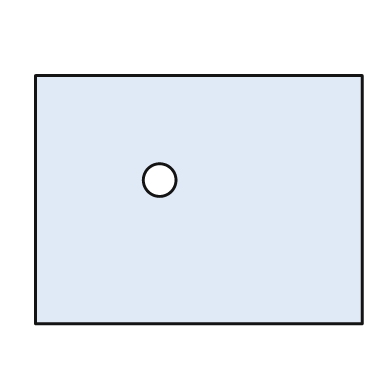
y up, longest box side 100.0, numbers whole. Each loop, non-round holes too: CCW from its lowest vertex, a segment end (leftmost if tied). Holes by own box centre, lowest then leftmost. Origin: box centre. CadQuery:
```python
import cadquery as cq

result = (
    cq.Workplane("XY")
    .moveTo(-50.0, -38.0)
    .lineTo(50.0, -38.0)
    .lineTo(50.0, 38.0)
    .lineTo(-50.0, 38.0)
    .close()
    .moveTo(-12.0, 6.0)
    .circle(5.0)
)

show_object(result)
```